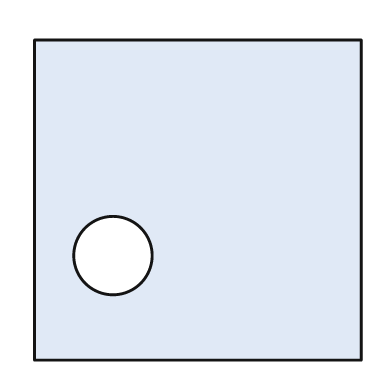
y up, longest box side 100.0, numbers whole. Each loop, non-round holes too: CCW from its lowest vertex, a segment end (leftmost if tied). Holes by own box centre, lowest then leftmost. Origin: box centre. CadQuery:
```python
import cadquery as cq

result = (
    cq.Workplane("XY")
    .moveTo(-50.0, -49.0)
    .lineTo(50.0, -49.0)
    .lineTo(50.0, 49.0)
    .lineTo(-50.0, 49.0)
    .close()
    .moveTo(-26.0, -17.0)
    .circle(12.0)
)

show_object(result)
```